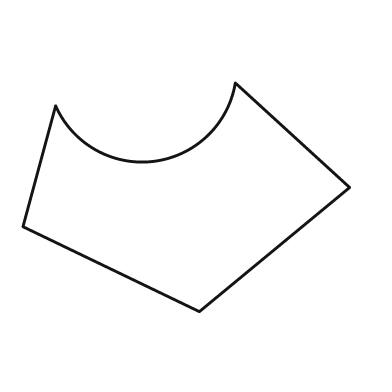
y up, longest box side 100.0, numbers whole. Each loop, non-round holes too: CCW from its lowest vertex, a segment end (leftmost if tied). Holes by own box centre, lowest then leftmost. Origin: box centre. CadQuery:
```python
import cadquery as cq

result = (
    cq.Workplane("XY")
    .moveTo(4.0, -35.0)
    .lineTo(50.0, 3.0)
    .lineTo(15.0, 35.0)
    .threePointArc((-10.0, 11.0), (-40.0, 28.0))
    .lineTo(-50.0, -9.0)
    .close()
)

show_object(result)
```